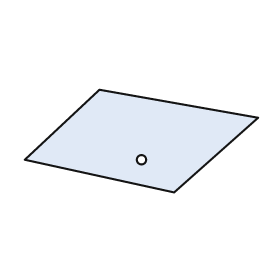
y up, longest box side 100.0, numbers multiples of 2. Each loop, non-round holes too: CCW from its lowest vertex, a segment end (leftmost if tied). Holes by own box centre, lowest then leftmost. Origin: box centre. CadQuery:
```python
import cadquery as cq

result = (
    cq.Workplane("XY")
    .moveTo(14.0, -22.0)
    .lineTo(50.0, 10.0)
    .lineTo(-18.0, 22.0)
    .lineTo(-50.0, -8.0)
    .close()
    .moveTo(0.0, -8.0)
    .circle(2.0)
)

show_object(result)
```